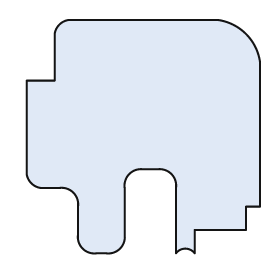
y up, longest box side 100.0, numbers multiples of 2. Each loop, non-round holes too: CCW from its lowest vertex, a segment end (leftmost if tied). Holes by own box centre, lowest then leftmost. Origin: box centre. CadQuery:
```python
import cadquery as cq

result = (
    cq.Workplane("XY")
    .moveTo(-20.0, -50.0)
    .lineTo(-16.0, -50.0)
    .threePointArc((-10.0, -48.0), (-8.0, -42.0))
    .lineTo(-8.0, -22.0)
    .threePointArc((-6.0, -16.0), (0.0, -14.0))
    .lineTo(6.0, -14.0)
    .threePointArc((12.0, -16.0), (14.0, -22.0))
    .lineTo(14.0, -50.0)
    .threePointArc((18.0, -48.0), (22.0, -50.0))
    .lineTo(22.0, -40.0)
    .lineTo(44.0, -40.0)
    .lineTo(44.0, -30.0)
    .lineTo(50.0, -30.0)
    .lineTo(50.0, 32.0)
    .threePointArc((44.0, 44.0), (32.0, 50.0))
    .lineTo(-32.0, 50.0)
    .threePointArc((-36.0, 48.0), (-38.0, 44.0))
    .lineTo(-38.0, 24.0)
    .lineTo(-50.0, 24.0)
    .lineTo(-50.0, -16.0)
    .threePointArc((-48.0, -20.0), (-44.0, -22.0))
    .lineTo(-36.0, -22.0)
    .threePointArc((-30.0, -24.0), (-28.0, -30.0))
    .lineTo(-28.0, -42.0)
    .threePointArc((-26.0, -48.0), (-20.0, -50.0))
    .close()
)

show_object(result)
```